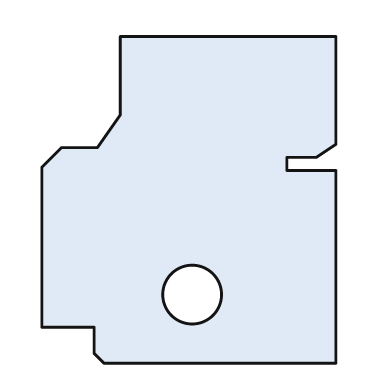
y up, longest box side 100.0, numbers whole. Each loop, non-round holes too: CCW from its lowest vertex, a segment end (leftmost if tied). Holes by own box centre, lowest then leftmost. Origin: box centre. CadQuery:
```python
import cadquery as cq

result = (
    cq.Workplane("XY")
    .moveTo(-26.0, -50.0)
    .lineTo(45.0, -50.0)
    .lineTo(45.0, 9.0)
    .lineTo(30.0, 9.0)
    .lineTo(30.0, 13.0)
    .lineTo(39.0, 13.0)
    .lineTo(45.0, 17.0)
    .lineTo(45.0, 50.0)
    .lineTo(-21.0, 50.0)
    .lineTo(-21.0, 26.0)
    .lineTo(-28.0, 16.0)
    .lineTo(-39.0, 16.0)
    .lineTo(-45.0, 10.0)
    .lineTo(-45.0, -39.0)
    .lineTo(-29.0, -39.0)
    .lineTo(-29.0, -47.0)
    .close()
    .moveTo(1.0, -29.0)
    .circle(9.0)
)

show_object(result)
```